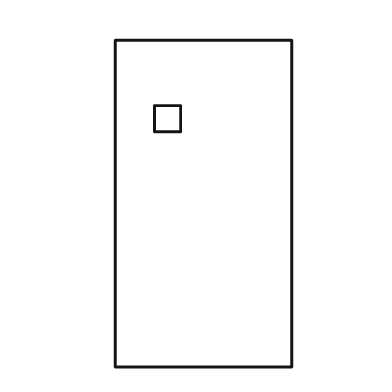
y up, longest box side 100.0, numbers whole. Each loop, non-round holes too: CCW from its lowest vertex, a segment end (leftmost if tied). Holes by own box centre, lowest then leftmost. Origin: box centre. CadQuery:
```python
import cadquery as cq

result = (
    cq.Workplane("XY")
    .moveTo(-27.0, -50.0)
    .lineTo(27.0, -50.0)
    .lineTo(27.0, 50.0)
    .lineTo(-27.0, 50.0)
    .close()
    .moveTo(-15.0, 22.0)
    .lineTo(-7.0, 22.0)
    .lineTo(-7.0, 30.0)
    .lineTo(-15.0, 30.0)
    .close()
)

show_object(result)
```